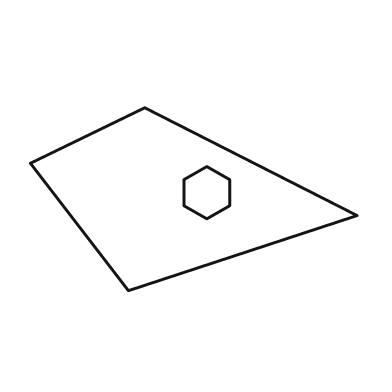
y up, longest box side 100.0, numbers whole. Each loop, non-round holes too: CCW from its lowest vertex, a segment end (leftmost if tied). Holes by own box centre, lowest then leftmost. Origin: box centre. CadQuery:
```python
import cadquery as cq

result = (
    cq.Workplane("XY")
    .moveTo(-20.0, -28.0)
    .lineTo(50.0, -5.0)
    .lineTo(-15.0, 28.0)
    .lineTo(-50.0, 11.0)
    .close()
    .moveTo(4.0, -6.0)
    .lineTo(11.0, -2.0)
    .lineTo(11.0, 6.0)
    .lineTo(4.0, 10.0)
    .lineTo(-3.0, 6.0)
    .lineTo(-3.0, -2.0)
    .close()
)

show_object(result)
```